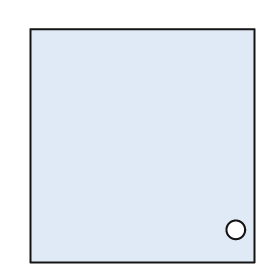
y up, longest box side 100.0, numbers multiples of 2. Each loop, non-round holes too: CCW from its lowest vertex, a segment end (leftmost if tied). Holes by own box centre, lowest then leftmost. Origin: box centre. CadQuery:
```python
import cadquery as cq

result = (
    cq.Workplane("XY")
    .moveTo(-48.0, -50.0)
    .lineTo(48.0, -50.0)
    .lineTo(48.0, 50.0)
    .lineTo(-48.0, 50.0)
    .close()
    .moveTo(40.0, -36.0)
    .circle(4.0)
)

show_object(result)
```